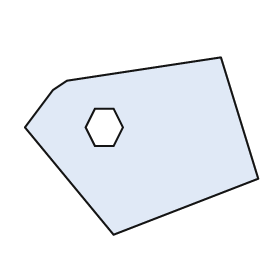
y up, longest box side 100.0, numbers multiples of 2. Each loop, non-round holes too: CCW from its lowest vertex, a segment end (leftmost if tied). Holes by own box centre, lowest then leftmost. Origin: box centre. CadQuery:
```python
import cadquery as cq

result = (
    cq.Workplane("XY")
    .moveTo(-12.0, -38.0)
    .lineTo(50.0, -14.0)
    .lineTo(34.0, 38.0)
    .lineTo(-32.0, 28.0)
    .lineTo(-38.0, 24.0)
    .lineTo(-50.0, 8.0)
    .close()
    .moveTo(-20.0, 0.0)
    .lineTo(-12.0, 0.0)
    .lineTo(-8.0, 8.0)
    .lineTo(-12.0, 16.0)
    .lineTo(-20.0, 16.0)
    .lineTo(-24.0, 8.0)
    .close()
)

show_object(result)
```